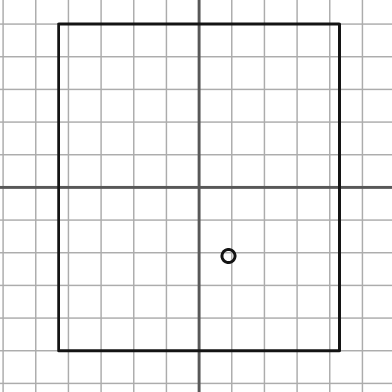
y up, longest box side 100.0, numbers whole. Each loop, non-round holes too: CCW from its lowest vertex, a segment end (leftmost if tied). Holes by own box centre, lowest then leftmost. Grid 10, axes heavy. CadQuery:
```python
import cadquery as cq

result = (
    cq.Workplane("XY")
    .moveTo(-43.0, -50.0)
    .lineTo(43.0, -50.0)
    .lineTo(43.0, 50.0)
    .lineTo(-43.0, 50.0)
    .close()
    .moveTo(9.0, -21.0)
    .circle(2.0)
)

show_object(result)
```